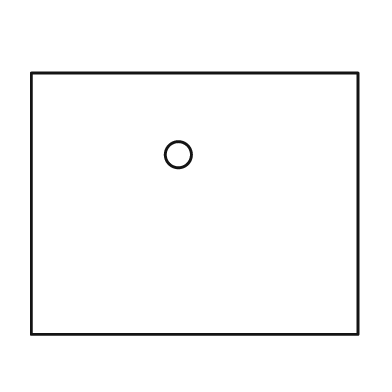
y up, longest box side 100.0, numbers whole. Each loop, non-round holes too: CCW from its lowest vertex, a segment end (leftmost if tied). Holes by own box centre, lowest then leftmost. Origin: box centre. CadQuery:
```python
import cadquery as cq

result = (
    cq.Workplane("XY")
    .moveTo(-50.0, -40.0)
    .lineTo(50.0, -40.0)
    .lineTo(50.0, 40.0)
    .lineTo(-50.0, 40.0)
    .close()
    .moveTo(-5.0, 15.0)
    .circle(4.0)
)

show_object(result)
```